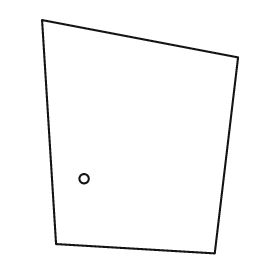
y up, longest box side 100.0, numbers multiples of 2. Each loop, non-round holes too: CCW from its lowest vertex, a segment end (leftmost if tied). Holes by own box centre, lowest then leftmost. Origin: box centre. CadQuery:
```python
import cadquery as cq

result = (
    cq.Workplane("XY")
    .moveTo(32.0, -50.0)
    .lineTo(42.0, 34.0)
    .lineTo(-42.0, 50.0)
    .lineTo(-36.0, -46.0)
    .close()
    .moveTo(-24.0, -18.0)
    .circle(2.0)
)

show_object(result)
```